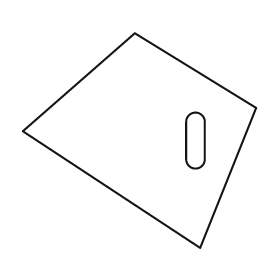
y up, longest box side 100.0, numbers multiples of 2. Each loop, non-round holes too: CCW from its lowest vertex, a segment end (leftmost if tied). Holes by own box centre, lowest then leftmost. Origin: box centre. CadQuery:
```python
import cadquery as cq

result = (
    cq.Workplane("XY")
    .moveTo(26.0, -46.0)
    .lineTo(50.0, 14.0)
    .lineTo(-2.0, 46.0)
    .lineTo(-50.0, 4.0)
    .close()
    .moveTo(20.0, -8.0)
    .threePointArc((24.0, -12.0), (28.0, -8.0))
    .lineTo(28.0, 8.0)
    .threePointArc((24.0, 12.0), (20.0, 8.0))
    .close()
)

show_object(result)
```